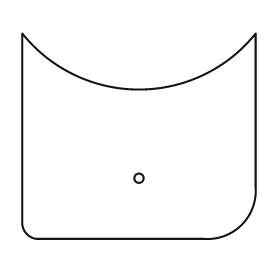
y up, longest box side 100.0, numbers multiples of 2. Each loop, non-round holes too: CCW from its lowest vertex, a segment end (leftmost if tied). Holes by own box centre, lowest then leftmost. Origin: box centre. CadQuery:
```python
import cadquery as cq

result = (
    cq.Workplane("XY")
    .moveTo(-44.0, -44.0)
    .lineTo(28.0, -44.0)
    .threePointArc((44.0, -38.0), (50.0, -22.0))
    .lineTo(50.0, 44.0)
    .threePointArc((0.0, 20.0), (-50.0, 44.0))
    .lineTo(-50.0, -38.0)
    .threePointArc((-48.0, -42.0), (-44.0, -44.0))
    .close()
    .moveTo(0.0, -18.0)
    .circle(2.0)
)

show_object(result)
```